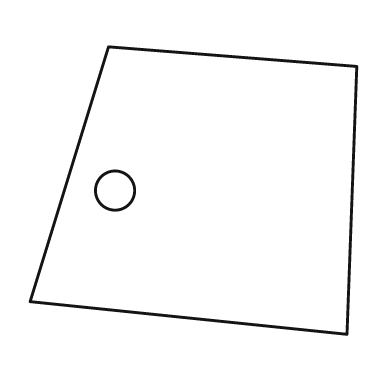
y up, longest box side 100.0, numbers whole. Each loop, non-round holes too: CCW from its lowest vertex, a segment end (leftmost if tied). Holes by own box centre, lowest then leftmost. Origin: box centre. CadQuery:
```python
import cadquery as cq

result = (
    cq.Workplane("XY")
    .moveTo(47.0, -44.0)
    .lineTo(50.0, 38.0)
    .lineTo(-26.0, 44.0)
    .lineTo(-50.0, -34.0)
    .close()
    .moveTo(-24.0, 0.0)
    .circle(6.0)
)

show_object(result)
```